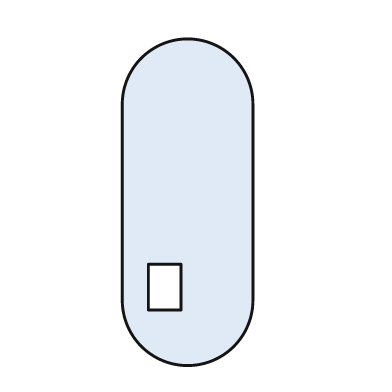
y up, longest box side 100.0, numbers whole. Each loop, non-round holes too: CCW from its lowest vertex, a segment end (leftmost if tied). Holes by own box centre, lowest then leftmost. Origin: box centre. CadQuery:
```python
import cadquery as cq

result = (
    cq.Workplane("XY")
    .moveTo(-20.0, -30.0)
    .threePointArc((0.0, -50.0), (20.0, -30.0))
    .lineTo(20.0, 30.0)
    .threePointArc((0.0, 50.0), (-20.0, 30.0))
    .close()
    .moveTo(-12.0, -33.0)
    .lineTo(-2.0, -33.0)
    .lineTo(-2.0, -19.0)
    .lineTo(-12.0, -19.0)
    .close()
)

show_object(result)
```